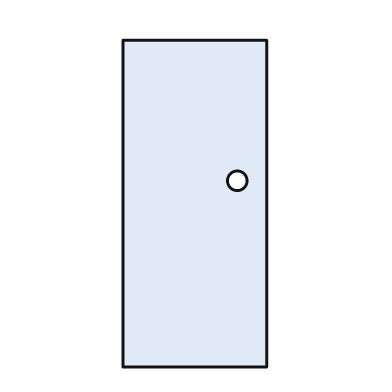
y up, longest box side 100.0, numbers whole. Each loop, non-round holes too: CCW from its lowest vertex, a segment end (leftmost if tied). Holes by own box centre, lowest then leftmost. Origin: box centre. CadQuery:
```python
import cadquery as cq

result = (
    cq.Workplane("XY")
    .moveTo(-22.0, -50.0)
    .lineTo(22.0, -50.0)
    .lineTo(22.0, 50.0)
    .lineTo(-22.0, 50.0)
    .close()
    .moveTo(13.0, 7.0)
    .circle(3.0)
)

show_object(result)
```